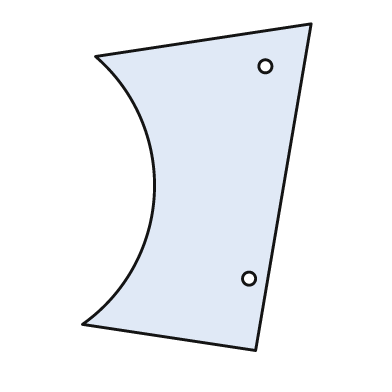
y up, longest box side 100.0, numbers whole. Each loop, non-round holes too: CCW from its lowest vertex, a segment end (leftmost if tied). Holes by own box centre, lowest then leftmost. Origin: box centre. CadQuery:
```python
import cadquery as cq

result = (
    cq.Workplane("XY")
    .moveTo(18.0, -50.0)
    .lineTo(35.0, 50.0)
    .lineTo(-31.0, 40.0)
    .threePointArc((-13.0, -2.0), (-35.0, -42.0))
    .close()
    .moveTo(16.0, -28.0)
    .circle(2.0)
    .moveTo(21.0, 37.0)
    .circle(2.0)
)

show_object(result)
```